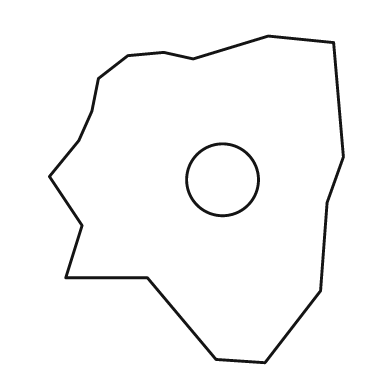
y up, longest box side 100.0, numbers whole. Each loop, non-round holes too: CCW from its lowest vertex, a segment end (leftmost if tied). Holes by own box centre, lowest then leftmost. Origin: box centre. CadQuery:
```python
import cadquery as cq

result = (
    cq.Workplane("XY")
    .moveTo(21.0, -50.0)
    .lineTo(38.0, -28.0)
    .lineTo(40.0, -1.0)
    .lineTo(45.0, 13.0)
    .lineTo(42.0, 48.0)
    .lineTo(22.0, 50.0)
    .lineTo(-1.0, 43.0)
    .lineTo(-10.0, 45.0)
    .lineTo(-21.0, 44.0)
    .lineTo(-30.0, 37.0)
    .lineTo(-32.0, 27.0)
    .lineTo(-36.0, 18.0)
    .lineTo(-45.0, 7.0)
    .lineTo(-35.0, -8.0)
    .lineTo(-40.0, -24.0)
    .lineTo(-15.0, -24.0)
    .lineTo(6.0, -49.0)
    .close()
    .moveTo(8.0, 6.0)
    .circle(11.0)
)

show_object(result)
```